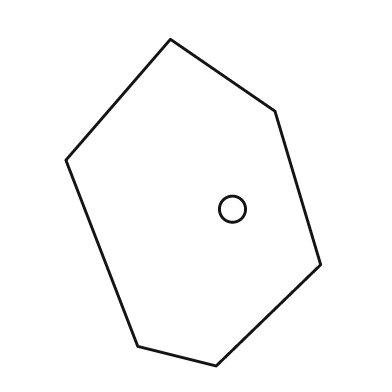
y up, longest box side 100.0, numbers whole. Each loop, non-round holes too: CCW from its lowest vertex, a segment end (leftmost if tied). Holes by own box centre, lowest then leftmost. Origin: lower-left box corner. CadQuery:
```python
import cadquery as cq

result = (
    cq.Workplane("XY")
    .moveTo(46.0, 0.0)
    .lineTo(78.0, 31.0)
    .lineTo(64.0, 78.0)
    .lineTo(32.0, 100.0)
    .lineTo(0.0, 63.0)
    .lineTo(22.0, 6.0)
    .close()
    .moveTo(51.0, 48.0)
    .circle(4.0)
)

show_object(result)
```